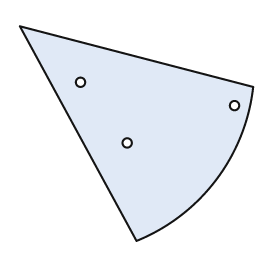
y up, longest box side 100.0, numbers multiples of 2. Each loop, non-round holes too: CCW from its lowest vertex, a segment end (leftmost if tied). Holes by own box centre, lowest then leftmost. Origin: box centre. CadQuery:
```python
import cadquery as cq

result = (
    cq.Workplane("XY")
    .moveTo(0.0, -46.0)
    .threePointArc((34.0, -20.0), (50.0, 20.0))
    .lineTo(-50.0, 46.0)
    .close()
    .moveTo(-4.0, -4.0)
    .circle(2.0)
    .moveTo(42.0, 12.0)
    .circle(2.0)
    .moveTo(-24.0, 22.0)
    .circle(2.0)
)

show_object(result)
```